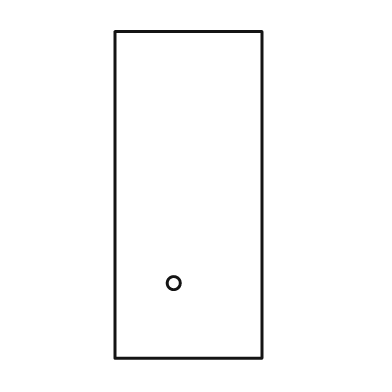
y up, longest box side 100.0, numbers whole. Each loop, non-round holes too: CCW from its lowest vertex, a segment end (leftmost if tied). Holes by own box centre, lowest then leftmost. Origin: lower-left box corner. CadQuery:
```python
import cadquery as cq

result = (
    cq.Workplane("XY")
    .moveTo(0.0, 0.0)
    .lineTo(45.0, 0.0)
    .lineTo(45.0, 100.0)
    .lineTo(0.0, 100.0)
    .close()
    .moveTo(18.0, 23.0)
    .circle(2.0)
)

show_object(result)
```